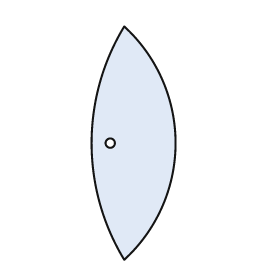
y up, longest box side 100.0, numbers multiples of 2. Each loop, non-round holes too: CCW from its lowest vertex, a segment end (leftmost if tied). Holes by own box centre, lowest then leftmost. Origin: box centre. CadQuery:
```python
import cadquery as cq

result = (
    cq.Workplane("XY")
    .moveTo(-4.0, -50.0)
    .threePointArc((18.0, 0.0), (-4.0, 50.0))
    .threePointArc((-18.0, 0.0), (-4.0, -50.0))
    .close()
    .moveTo(-10.0, 0.0)
    .circle(2.0)
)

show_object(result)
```